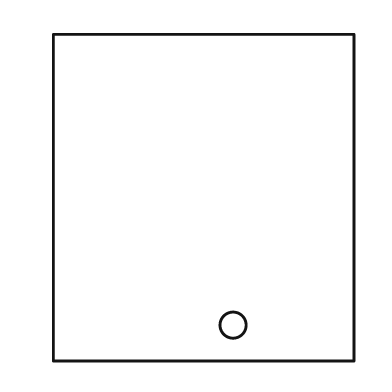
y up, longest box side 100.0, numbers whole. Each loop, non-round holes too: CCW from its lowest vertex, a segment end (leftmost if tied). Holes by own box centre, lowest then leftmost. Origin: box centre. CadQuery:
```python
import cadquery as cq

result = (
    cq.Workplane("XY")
    .moveTo(-46.0, -50.0)
    .lineTo(46.0, -50.0)
    .lineTo(46.0, 50.0)
    .lineTo(-46.0, 50.0)
    .close()
    .moveTo(9.0, -39.0)
    .circle(4.0)
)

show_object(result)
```